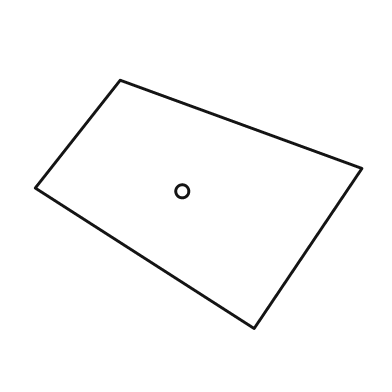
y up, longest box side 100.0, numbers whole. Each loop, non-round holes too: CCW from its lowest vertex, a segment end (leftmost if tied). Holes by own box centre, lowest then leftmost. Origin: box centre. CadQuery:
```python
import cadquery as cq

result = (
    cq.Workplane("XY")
    .moveTo(17.0, -38.0)
    .lineTo(50.0, 11.0)
    .lineTo(-24.0, 38.0)
    .lineTo(-50.0, 5.0)
    .close()
    .moveTo(-5.0, 4.0)
    .circle(2.0)
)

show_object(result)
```